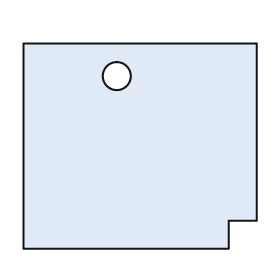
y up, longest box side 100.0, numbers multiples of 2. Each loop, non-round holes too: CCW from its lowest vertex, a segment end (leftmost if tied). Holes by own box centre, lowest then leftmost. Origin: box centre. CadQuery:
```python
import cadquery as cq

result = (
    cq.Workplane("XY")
    .moveTo(-50.0, -44.0)
    .lineTo(38.0, -44.0)
    .lineTo(38.0, -32.0)
    .lineTo(50.0, -32.0)
    .lineTo(50.0, 44.0)
    .lineTo(-50.0, 44.0)
    .close()
    .moveTo(-10.0, 30.0)
    .circle(6.0)
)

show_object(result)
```